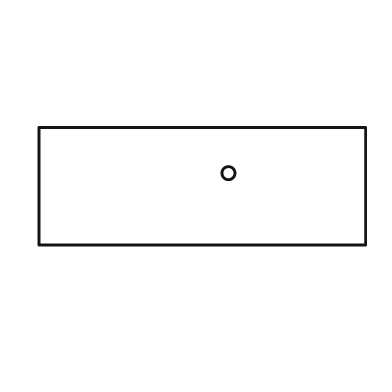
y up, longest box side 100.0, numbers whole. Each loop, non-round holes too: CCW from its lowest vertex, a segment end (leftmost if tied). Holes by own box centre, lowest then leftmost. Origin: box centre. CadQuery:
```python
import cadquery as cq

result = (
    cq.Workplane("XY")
    .moveTo(-50.0, -18.0)
    .lineTo(50.0, -18.0)
    .lineTo(50.0, 18.0)
    .lineTo(-50.0, 18.0)
    .close()
    .moveTo(8.0, 4.0)
    .circle(2.0)
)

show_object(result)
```